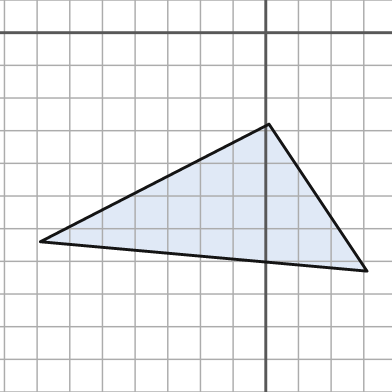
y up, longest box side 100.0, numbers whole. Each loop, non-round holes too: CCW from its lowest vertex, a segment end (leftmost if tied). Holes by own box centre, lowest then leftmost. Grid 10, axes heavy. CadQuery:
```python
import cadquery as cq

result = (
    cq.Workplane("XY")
    .moveTo(31.0, -73.0)
    .lineTo(1.0, -28.0)
    .lineTo(-69.0, -64.0)
    .close()
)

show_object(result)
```